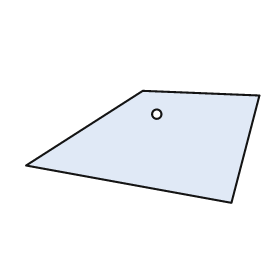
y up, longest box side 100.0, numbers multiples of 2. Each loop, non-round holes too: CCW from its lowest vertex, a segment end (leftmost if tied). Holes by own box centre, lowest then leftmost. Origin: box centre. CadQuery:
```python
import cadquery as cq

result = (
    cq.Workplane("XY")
    .moveTo(38.0, -24.0)
    .lineTo(50.0, 22.0)
    .lineTo(0.0, 24.0)
    .lineTo(-50.0, -8.0)
    .close()
    .moveTo(6.0, 14.0)
    .circle(2.0)
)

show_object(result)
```